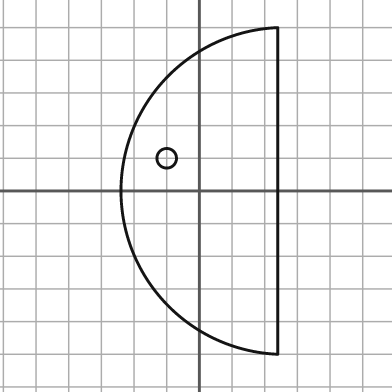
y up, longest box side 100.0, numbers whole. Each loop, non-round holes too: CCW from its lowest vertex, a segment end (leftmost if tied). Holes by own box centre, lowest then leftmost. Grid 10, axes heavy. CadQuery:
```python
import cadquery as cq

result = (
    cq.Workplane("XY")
    .moveTo(24.0, -50.0)
    .lineTo(24.0, 50.0)
    .threePointArc((-24.0, 0.0), (24.0, -50.0))
    .close()
    .moveTo(-10.0, 10.0)
    .circle(3.0)
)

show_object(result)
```